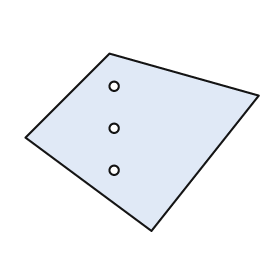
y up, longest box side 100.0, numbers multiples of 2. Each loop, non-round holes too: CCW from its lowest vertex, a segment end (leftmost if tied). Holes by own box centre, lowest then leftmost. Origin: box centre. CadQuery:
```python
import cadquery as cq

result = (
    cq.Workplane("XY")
    .moveTo(4.0, -38.0)
    .lineTo(50.0, 20.0)
    .lineTo(-14.0, 38.0)
    .lineTo(-50.0, 2.0)
    .close()
    .moveTo(-12.0, -12.0)
    .circle(2.0)
    .moveTo(-12.0, 6.0)
    .circle(2.0)
    .moveTo(-12.0, 24.0)
    .circle(2.0)
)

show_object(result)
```